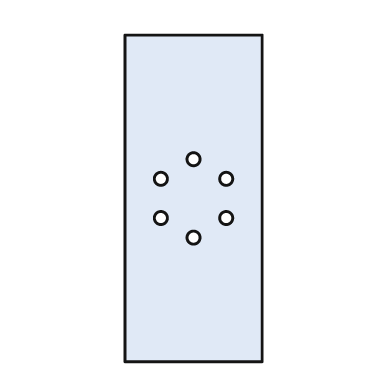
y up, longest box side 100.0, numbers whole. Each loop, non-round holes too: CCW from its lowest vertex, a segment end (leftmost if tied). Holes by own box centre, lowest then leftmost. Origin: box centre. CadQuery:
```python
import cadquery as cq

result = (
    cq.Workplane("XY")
    .moveTo(-21.0, -50.0)
    .lineTo(21.0, -50.0)
    .lineTo(21.0, 50.0)
    .lineTo(-21.0, 50.0)
    .close()
    .moveTo(0.0, -12.0)
    .circle(2.0)
    .moveTo(-10.0, -6.0)
    .circle(2.0)
    .moveTo(10.0, -6.0)
    .circle(2.0)
    .moveTo(-10.0, 6.0)
    .circle(2.0)
    .moveTo(10.0, 6.0)
    .circle(2.0)
    .moveTo(0.0, 12.0)
    .circle(2.0)
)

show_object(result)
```